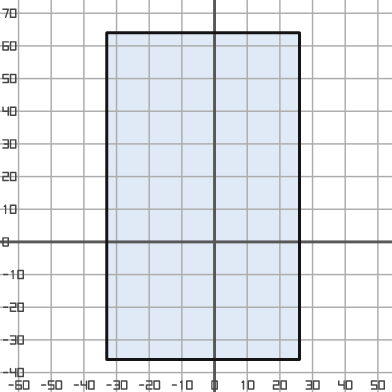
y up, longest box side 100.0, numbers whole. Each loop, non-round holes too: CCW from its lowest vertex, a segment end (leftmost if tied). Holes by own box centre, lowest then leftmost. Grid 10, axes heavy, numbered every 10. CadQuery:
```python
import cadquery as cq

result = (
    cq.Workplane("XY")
    .moveTo(-33.0, -36.0)
    .lineTo(26.0, -36.0)
    .lineTo(26.0, 64.0)
    .lineTo(-33.0, 64.0)
    .close()
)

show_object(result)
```